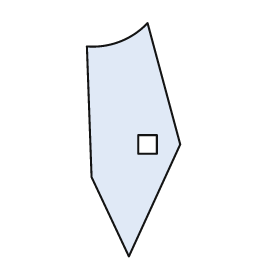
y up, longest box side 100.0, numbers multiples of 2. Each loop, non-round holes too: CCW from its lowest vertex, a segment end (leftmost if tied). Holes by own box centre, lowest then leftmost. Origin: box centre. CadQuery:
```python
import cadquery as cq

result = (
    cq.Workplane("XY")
    .moveTo(-2.0, -50.0)
    .lineTo(20.0, -2.0)
    .lineTo(6.0, 50.0)
    .threePointArc((-6.0, 42.0), (-20.0, 40.0))
    .lineTo(-18.0, -16.0)
    .close()
    .moveTo(2.0, -6.0)
    .lineTo(10.0, -6.0)
    .lineTo(10.0, 2.0)
    .lineTo(2.0, 2.0)
    .close()
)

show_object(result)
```